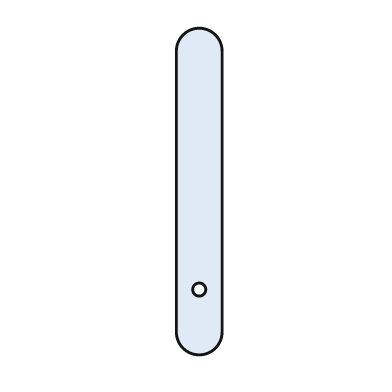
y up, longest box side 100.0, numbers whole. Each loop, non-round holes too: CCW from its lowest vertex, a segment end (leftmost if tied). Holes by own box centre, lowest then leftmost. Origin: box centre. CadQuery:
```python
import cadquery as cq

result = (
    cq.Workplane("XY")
    .moveTo(-7.0, -43.0)
    .threePointArc((0.0, -50.0), (7.0, -43.0))
    .lineTo(7.0, 43.0)
    .threePointArc((0.0, 50.0), (-7.0, 43.0))
    .close()
    .moveTo(0.0, -30.0)
    .circle(2.0)
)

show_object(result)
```